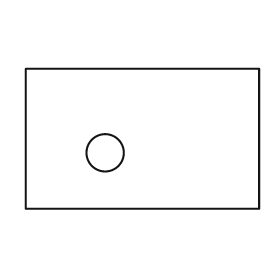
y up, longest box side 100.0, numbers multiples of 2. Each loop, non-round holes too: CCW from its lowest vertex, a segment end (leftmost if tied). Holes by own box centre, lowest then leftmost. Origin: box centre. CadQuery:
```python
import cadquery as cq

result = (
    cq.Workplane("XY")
    .moveTo(-50.0, -30.0)
    .lineTo(50.0, -30.0)
    .lineTo(50.0, 30.0)
    .lineTo(-50.0, 30.0)
    .close()
    .moveTo(-16.0, -6.0)
    .circle(8.0)
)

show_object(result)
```